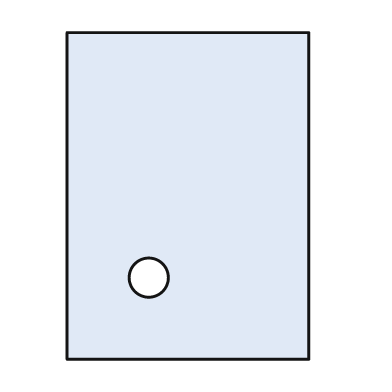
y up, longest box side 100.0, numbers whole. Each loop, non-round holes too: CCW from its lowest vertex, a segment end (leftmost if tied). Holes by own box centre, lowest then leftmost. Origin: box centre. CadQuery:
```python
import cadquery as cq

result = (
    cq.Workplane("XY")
    .moveTo(-37.0, -50.0)
    .lineTo(37.0, -50.0)
    .lineTo(37.0, 50.0)
    .lineTo(-37.0, 50.0)
    .close()
    .moveTo(-12.0, -25.0)
    .circle(6.0)
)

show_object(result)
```